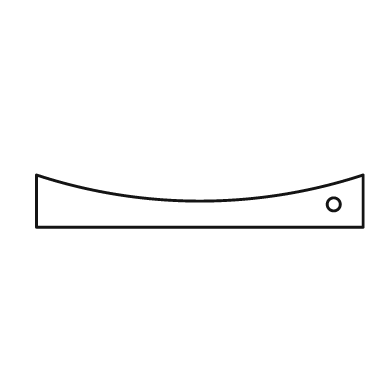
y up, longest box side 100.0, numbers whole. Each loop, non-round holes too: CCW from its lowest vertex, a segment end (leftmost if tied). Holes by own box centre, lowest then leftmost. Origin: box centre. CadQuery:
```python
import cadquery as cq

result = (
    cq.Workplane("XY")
    .moveTo(-50.0, -8.0)
    .lineTo(50.0, -8.0)
    .lineTo(50.0, 8.0)
    .threePointArc((0.0, 0.0), (-50.0, 8.0))
    .close()
    .moveTo(41.0, -1.0)
    .circle(2.0)
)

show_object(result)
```